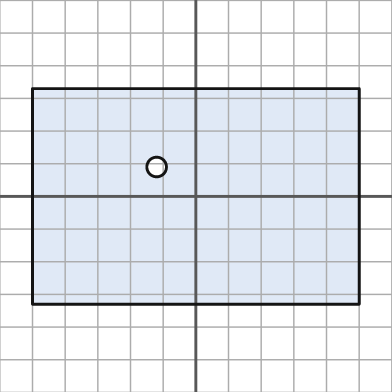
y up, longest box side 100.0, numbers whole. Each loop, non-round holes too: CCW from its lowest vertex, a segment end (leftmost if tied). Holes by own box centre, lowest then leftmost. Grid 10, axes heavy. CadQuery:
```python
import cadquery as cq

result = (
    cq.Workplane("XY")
    .moveTo(-50.0, -33.0)
    .lineTo(50.0, -33.0)
    .lineTo(50.0, 33.0)
    .lineTo(-50.0, 33.0)
    .close()
    .moveTo(-12.0, 9.0)
    .circle(3.0)
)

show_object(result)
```